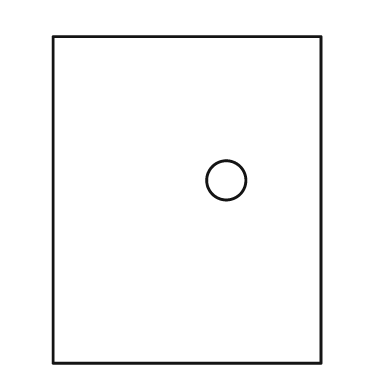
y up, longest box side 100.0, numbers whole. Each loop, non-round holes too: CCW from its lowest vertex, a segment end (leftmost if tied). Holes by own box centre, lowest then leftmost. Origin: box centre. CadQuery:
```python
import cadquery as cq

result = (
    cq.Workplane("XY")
    .moveTo(-41.0, -50.0)
    .lineTo(41.0, -50.0)
    .lineTo(41.0, 50.0)
    .lineTo(-41.0, 50.0)
    .close()
    .moveTo(12.0, 6.0)
    .circle(6.0)
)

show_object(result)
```